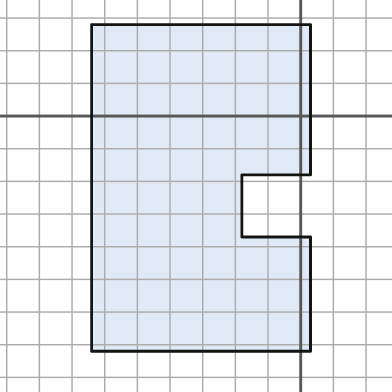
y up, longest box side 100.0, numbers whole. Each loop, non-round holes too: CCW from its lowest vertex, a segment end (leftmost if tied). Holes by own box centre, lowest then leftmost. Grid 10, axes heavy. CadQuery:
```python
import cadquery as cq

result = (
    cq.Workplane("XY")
    .moveTo(-64.0, -72.0)
    .lineTo(3.0, -72.0)
    .lineTo(3.0, -37.0)
    .lineTo(-18.0, -37.0)
    .lineTo(-18.0, -18.0)
    .lineTo(3.0, -18.0)
    .lineTo(3.0, 28.0)
    .lineTo(-64.0, 28.0)
    .close()
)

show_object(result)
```